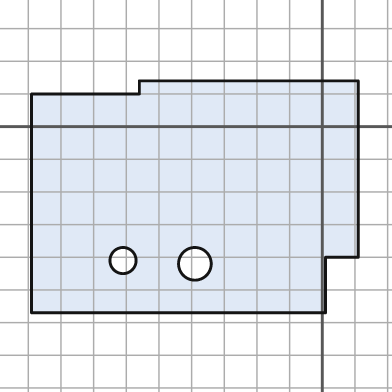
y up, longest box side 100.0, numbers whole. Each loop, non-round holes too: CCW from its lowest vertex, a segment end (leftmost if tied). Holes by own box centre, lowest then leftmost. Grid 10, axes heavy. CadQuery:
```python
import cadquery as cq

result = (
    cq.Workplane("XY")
    .moveTo(-89.0, -57.0)
    .lineTo(1.0, -57.0)
    .lineTo(1.0, -40.0)
    .lineTo(11.0, -40.0)
    .lineTo(11.0, 14.0)
    .lineTo(-56.0, 14.0)
    .lineTo(-56.0, 10.0)
    .lineTo(-89.0, 10.0)
    .close()
    .moveTo(-39.0, -42.0)
    .circle(5.0)
    .moveTo(-61.0, -41.0)
    .circle(4.0)
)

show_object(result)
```